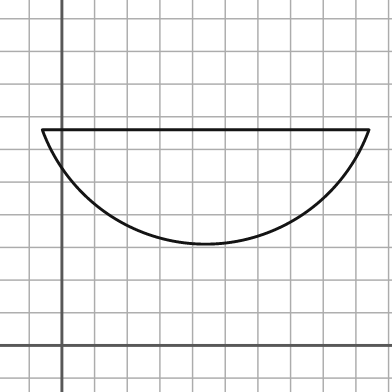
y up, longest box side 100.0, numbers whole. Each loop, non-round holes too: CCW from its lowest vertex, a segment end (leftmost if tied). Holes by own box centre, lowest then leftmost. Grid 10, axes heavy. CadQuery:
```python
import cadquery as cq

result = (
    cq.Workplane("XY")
    .moveTo(-6.0, 66.0)
    .threePointArc((44.0, 31.0), (94.0, 66.0))
    .close()
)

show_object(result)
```